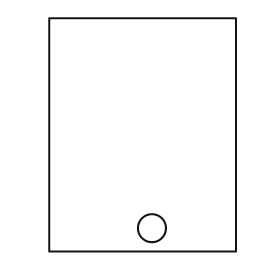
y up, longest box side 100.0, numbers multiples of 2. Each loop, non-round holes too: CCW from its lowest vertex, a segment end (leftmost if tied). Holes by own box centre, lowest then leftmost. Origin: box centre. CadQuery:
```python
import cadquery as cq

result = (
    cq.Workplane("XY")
    .moveTo(-40.0, -50.0)
    .lineTo(40.0, -50.0)
    .lineTo(40.0, 50.0)
    .lineTo(-40.0, 50.0)
    .close()
    .moveTo(4.0, -40.0)
    .circle(6.0)
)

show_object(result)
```